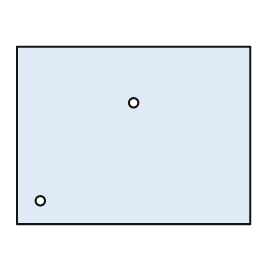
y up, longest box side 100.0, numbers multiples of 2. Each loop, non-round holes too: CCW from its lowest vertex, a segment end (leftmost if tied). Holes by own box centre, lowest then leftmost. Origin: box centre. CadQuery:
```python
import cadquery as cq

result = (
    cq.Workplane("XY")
    .moveTo(-50.0, -38.0)
    .lineTo(50.0, -38.0)
    .lineTo(50.0, 38.0)
    .lineTo(-50.0, 38.0)
    .close()
    .moveTo(-40.0, -28.0)
    .circle(2.0)
    .moveTo(0.0, 14.0)
    .circle(2.0)
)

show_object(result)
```